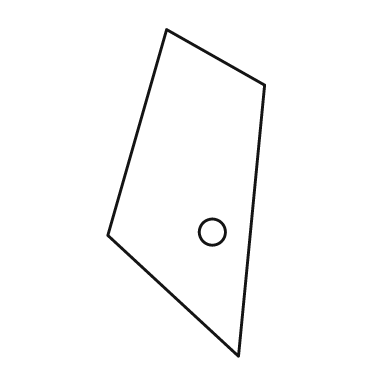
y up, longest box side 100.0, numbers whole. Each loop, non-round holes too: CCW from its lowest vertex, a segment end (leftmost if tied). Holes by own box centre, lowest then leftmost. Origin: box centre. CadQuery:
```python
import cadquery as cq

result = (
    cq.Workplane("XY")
    .moveTo(16.0, -50.0)
    .lineTo(24.0, 33.0)
    .lineTo(-6.0, 50.0)
    .lineTo(-24.0, -13.0)
    .close()
    .moveTo(8.0, -12.0)
    .circle(4.0)
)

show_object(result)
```